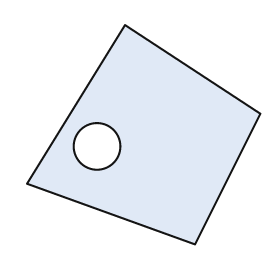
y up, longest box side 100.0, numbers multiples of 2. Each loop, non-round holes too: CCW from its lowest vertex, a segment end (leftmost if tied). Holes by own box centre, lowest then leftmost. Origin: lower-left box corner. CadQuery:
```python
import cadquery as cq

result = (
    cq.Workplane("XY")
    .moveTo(72.0, 0.0)
    .lineTo(100.0, 56.0)
    .lineTo(42.0, 94.0)
    .lineTo(0.0, 26.0)
    .close()
    .moveTo(30.0, 42.0)
    .circle(10.0)
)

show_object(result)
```